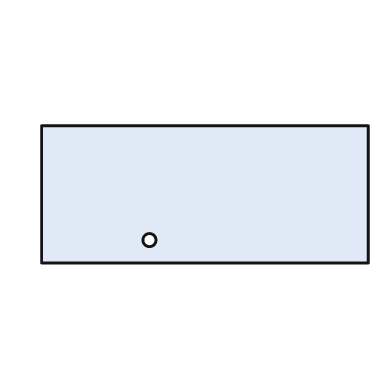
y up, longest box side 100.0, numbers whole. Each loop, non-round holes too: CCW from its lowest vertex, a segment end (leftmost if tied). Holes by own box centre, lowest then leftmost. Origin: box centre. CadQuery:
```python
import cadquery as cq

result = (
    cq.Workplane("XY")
    .moveTo(-50.0, -21.0)
    .lineTo(50.0, -21.0)
    .lineTo(50.0, 21.0)
    .lineTo(-50.0, 21.0)
    .close()
    .moveTo(-17.0, -14.0)
    .circle(2.0)
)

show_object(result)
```